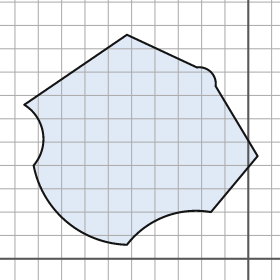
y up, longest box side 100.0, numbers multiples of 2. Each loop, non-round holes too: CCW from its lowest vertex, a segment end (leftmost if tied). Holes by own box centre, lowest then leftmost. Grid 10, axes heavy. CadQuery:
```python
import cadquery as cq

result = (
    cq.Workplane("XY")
    .moveTo(-52.0, 6.0)
    .threePointArc((-36.0, 18.0), (-16.0, 20.0))
    .lineTo(4.0, 44.0)
    .lineTo(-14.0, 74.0)
    .threePointArc((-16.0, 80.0), (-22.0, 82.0))
    .lineTo(-52.0, 96.0)
    .lineTo(-96.0, 66.0)
    .threePointArc((-88.0, 54.0), (-92.0, 40.0))
    .threePointArc((-78.0, 16.0), (-52.0, 6.0))
    .close()
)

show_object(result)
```